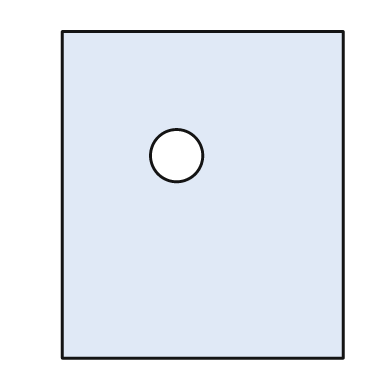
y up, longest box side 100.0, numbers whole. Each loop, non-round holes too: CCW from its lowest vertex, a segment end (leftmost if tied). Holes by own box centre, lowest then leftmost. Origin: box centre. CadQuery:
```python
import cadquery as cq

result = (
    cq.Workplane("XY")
    .moveTo(-43.0, -50.0)
    .lineTo(43.0, -50.0)
    .lineTo(43.0, 50.0)
    .lineTo(-43.0, 50.0)
    .close()
    .moveTo(-8.0, 12.0)
    .circle(8.0)
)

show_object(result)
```